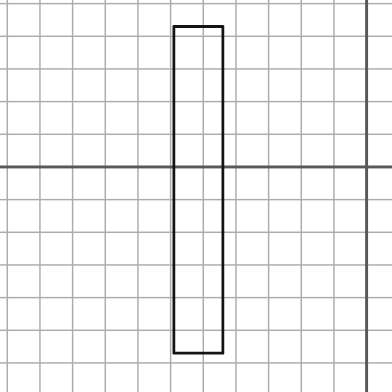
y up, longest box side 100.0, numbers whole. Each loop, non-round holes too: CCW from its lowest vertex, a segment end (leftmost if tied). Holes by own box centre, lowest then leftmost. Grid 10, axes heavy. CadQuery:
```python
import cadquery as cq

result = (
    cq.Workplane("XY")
    .moveTo(-59.0, -57.0)
    .lineTo(-44.0, -57.0)
    .lineTo(-44.0, 43.0)
    .lineTo(-59.0, 43.0)
    .close()
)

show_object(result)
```